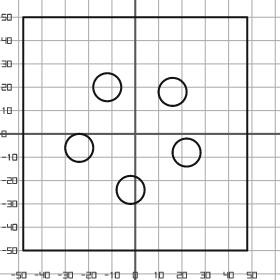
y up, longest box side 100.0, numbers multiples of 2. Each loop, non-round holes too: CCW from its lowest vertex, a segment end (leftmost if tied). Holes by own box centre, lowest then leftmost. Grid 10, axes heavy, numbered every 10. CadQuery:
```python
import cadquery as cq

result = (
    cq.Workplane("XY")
    .moveTo(-48.0, -50.0)
    .lineTo(48.0, -50.0)
    .lineTo(48.0, 50.0)
    .lineTo(-48.0, 50.0)
    .close()
    .moveTo(-2.0, -24.0)
    .circle(6.0)
    .moveTo(22.0, -8.0)
    .circle(6.0)
    .moveTo(-24.0, -6.0)
    .circle(6.0)
    .moveTo(16.0, 18.0)
    .circle(6.0)
    .moveTo(-12.0, 20.0)
    .circle(6.0)
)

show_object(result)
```